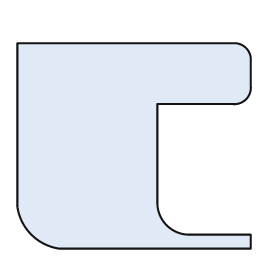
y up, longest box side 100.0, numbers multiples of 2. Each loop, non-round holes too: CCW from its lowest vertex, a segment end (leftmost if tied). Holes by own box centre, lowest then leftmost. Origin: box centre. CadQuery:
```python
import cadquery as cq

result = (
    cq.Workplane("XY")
    .moveTo(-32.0, -44.0)
    .lineTo(50.0, -44.0)
    .lineTo(50.0, -38.0)
    .lineTo(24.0, -38.0)
    .threePointArc((14.0, -34.0), (10.0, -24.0))
    .lineTo(10.0, 18.0)
    .lineTo(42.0, 18.0)
    .threePointArc((48.0, 20.0), (50.0, 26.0))
    .lineTo(50.0, 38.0)
    .threePointArc((48.0, 42.0), (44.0, 44.0))
    .lineTo(-50.0, 44.0)
    .lineTo(-50.0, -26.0)
    .threePointArc((-44.0, -38.0), (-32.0, -44.0))
    .close()
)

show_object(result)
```